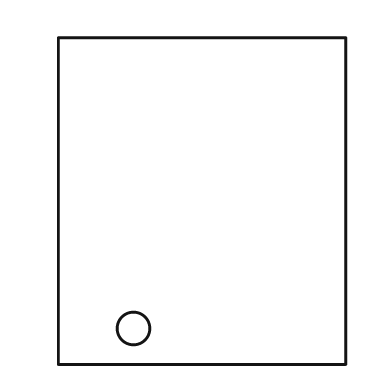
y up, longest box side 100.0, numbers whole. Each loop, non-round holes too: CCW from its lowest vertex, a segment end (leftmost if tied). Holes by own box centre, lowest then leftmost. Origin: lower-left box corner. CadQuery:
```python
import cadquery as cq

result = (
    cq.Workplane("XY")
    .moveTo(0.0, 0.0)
    .lineTo(88.0, 0.0)
    .lineTo(88.0, 100.0)
    .lineTo(0.0, 100.0)
    .close()
    .moveTo(23.0, 11.0)
    .circle(5.0)
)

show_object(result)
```